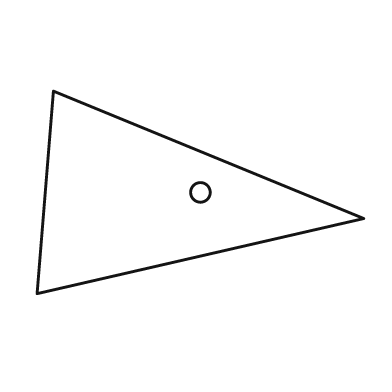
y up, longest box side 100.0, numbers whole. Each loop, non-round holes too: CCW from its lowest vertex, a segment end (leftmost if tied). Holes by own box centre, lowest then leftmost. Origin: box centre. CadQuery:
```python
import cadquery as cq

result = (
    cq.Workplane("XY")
    .moveTo(-50.0, -31.0)
    .lineTo(50.0, -8.0)
    .lineTo(-45.0, 31.0)
    .close()
    .moveTo(0.0, 0.0)
    .circle(3.0)
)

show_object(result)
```